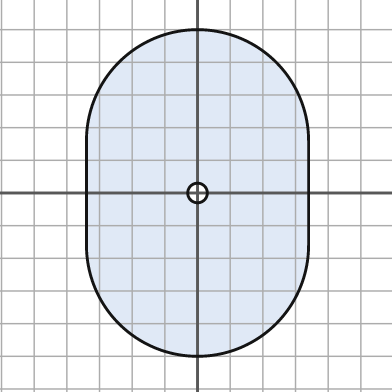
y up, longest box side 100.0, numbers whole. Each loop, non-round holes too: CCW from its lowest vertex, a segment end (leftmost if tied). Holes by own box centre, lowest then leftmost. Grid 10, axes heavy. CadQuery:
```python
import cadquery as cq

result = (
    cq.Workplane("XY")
    .moveTo(-34.0, -16.0)
    .threePointArc((0.0, -50.0), (34.0, -16.0))
    .lineTo(34.0, 16.0)
    .threePointArc((0.0, 50.0), (-34.0, 16.0))
    .close()
    .moveTo(0.0, 0.0)
    .circle(3.0)
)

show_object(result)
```